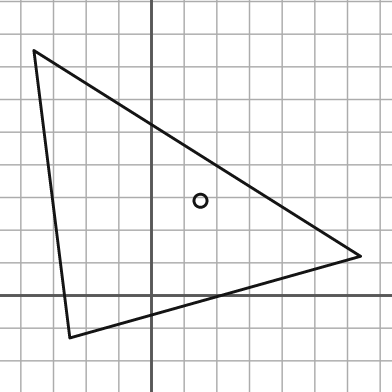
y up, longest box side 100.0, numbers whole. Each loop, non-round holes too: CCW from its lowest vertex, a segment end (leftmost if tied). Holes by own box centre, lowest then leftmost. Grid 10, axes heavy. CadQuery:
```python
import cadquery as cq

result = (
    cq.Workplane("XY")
    .moveTo(-25.0, -13.0)
    .lineTo(64.0, 12.0)
    .lineTo(-36.0, 75.0)
    .close()
    .moveTo(15.0, 29.0)
    .circle(2.0)
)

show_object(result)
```